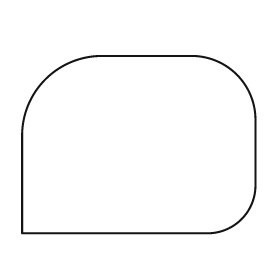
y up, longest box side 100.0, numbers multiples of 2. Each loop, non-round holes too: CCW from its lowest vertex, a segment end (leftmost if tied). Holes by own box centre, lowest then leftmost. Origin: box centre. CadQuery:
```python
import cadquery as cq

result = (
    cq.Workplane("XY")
    .moveTo(-50.0, -38.0)
    .lineTo(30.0, -38.0)
    .threePointArc((44.0, -32.0), (50.0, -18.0))
    .lineTo(50.0, 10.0)
    .threePointArc((42.0, 30.0), (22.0, 38.0))
    .lineTo(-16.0, 38.0)
    .threePointArc((-40.0, 28.0), (-50.0, 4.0))
    .close()
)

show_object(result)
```